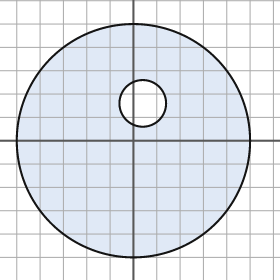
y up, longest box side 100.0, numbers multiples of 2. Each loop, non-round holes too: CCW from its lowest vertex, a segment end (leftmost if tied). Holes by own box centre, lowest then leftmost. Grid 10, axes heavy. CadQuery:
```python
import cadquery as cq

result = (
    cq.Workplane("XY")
    .moveTo(0.0, 0.0)
    .circle(50.0)
    .moveTo(4.0, 16.0)
    .circle(10.0)
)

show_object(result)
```